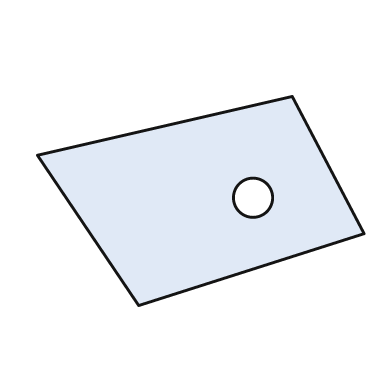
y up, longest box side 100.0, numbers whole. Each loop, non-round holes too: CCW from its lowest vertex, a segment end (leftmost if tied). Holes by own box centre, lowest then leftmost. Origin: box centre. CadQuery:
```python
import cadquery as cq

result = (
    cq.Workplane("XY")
    .moveTo(-19.0, -32.0)
    .lineTo(50.0, -10.0)
    .lineTo(28.0, 32.0)
    .lineTo(-50.0, 14.0)
    .close()
    .moveTo(16.0, 1.0)
    .circle(6.0)
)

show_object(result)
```